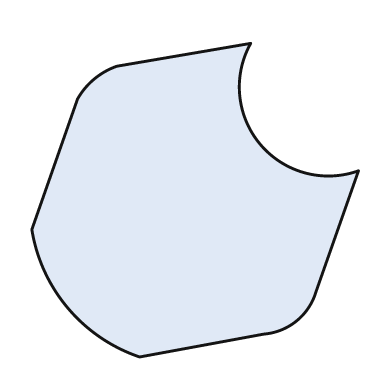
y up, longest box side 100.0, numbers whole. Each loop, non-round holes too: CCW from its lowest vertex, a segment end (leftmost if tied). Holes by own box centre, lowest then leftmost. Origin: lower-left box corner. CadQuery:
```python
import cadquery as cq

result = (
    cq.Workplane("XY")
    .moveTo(33.0, 0.0)
    .lineTo(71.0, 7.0)
    .threePointArc((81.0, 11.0), (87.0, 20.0))
    .lineTo(100.0, 57.0)
    .threePointArc((70.0, 65.0), (67.0, 96.0))
    .lineTo(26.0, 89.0)
    .threePointArc((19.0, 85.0), (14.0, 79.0))
    .lineTo(0.0, 39.0)
    .threePointArc((11.0, 15.0), (33.0, 0.0))
    .close()
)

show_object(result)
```